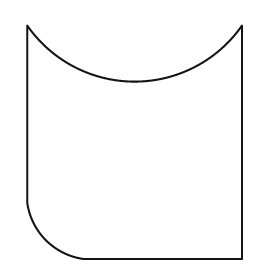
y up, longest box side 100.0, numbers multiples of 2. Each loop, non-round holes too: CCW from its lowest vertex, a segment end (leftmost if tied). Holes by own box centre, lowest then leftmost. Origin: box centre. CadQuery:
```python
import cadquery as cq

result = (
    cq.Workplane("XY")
    .moveTo(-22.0, -50.0)
    .lineTo(46.0, -50.0)
    .lineTo(46.0, 50.0)
    .threePointArc((0.0, 26.0), (-46.0, 50.0))
    .lineTo(-46.0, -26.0)
    .threePointArc((-38.0, -42.0), (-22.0, -50.0))
    .close()
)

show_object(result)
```